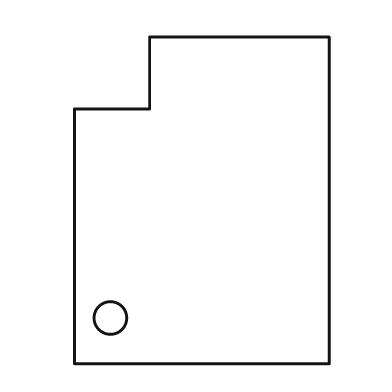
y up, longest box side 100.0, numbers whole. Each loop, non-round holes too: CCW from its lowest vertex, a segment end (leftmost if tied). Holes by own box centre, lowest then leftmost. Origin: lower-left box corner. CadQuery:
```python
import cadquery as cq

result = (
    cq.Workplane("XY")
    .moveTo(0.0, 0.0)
    .lineTo(78.0, 0.0)
    .lineTo(78.0, 100.0)
    .lineTo(23.0, 100.0)
    .lineTo(23.0, 78.0)
    .lineTo(0.0, 78.0)
    .close()
    .moveTo(11.0, 14.0)
    .circle(5.0)
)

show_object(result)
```